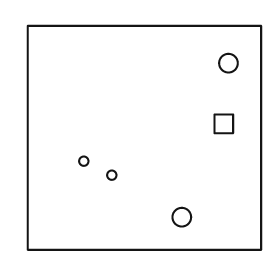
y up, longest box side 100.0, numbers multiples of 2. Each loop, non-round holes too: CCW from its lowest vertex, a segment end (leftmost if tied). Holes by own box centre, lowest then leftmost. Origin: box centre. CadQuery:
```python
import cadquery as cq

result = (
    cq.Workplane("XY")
    .moveTo(-50.0, -48.0)
    .lineTo(50.0, -48.0)
    .lineTo(50.0, 48.0)
    .lineTo(-50.0, 48.0)
    .close()
    .moveTo(16.0, -34.0)
    .circle(4.0)
    .moveTo(-14.0, -16.0)
    .circle(2.0)
    .moveTo(-26.0, -10.0)
    .circle(2.0)
    .moveTo(30.0, 2.0)
    .lineTo(38.0, 2.0)
    .lineTo(38.0, 10.0)
    .lineTo(30.0, 10.0)
    .close()
    .moveTo(36.0, 32.0)
    .circle(4.0)
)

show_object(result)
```